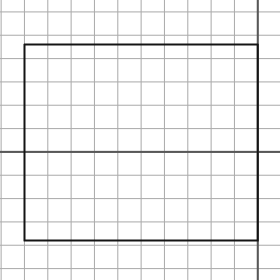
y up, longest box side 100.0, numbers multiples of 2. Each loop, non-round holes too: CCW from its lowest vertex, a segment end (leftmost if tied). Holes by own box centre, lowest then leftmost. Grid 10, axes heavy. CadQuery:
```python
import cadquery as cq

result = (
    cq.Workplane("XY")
    .moveTo(-100.0, -38.0)
    .lineTo(0.0, -38.0)
    .lineTo(0.0, 46.0)
    .lineTo(-100.0, 46.0)
    .close()
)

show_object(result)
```